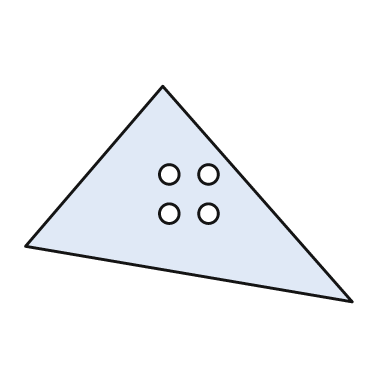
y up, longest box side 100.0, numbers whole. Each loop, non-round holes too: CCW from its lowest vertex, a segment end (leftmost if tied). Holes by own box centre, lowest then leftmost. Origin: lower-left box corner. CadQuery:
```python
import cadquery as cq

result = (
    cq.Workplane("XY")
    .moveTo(100.0, 0.0)
    .lineTo(42.0, 66.0)
    .lineTo(0.0, 17.0)
    .close()
    .moveTo(44.0, 27.0)
    .circle(3.0)
    .moveTo(56.0, 27.0)
    .circle(3.0)
    .moveTo(44.0, 39.0)
    .circle(3.0)
    .moveTo(56.0, 39.0)
    .circle(3.0)
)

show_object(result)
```